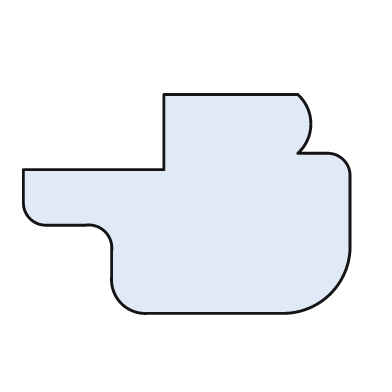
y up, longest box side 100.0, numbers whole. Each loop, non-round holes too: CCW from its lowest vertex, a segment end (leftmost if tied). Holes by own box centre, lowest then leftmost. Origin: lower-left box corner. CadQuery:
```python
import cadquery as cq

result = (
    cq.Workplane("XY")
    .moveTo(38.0, 0.0)
    .lineTo(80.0, 0.0)
    .threePointArc((94.0, 6.0), (100.0, 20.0))
    .lineTo(100.0, 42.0)
    .threePointArc((98.0, 47.0), (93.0, 49.0))
    .lineTo(84.0, 49.0)
    .threePointArc((88.0, 58.0), (84.0, 67.0))
    .lineTo(43.0, 67.0)
    .lineTo(43.0, 44.0)
    .lineTo(0.0, 44.0)
    .lineTo(0.0, 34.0)
    .threePointArc((2.0, 29.0), (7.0, 27.0))
    .lineTo(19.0, 27.0)
    .threePointArc((25.0, 25.0), (27.0, 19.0))
    .lineTo(27.0, 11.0)
    .threePointArc((30.0, 3.0), (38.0, 0.0))
    .close()
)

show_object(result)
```